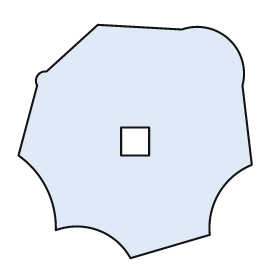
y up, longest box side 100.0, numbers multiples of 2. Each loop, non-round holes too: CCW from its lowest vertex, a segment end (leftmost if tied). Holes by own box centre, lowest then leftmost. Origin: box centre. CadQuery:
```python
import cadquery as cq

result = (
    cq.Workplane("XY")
    .moveTo(-2.0, -50.0)
    .lineTo(32.0, -40.0)
    .threePointArc((36.0, -22.0), (50.0, -10.0))
    .lineTo(46.0, 24.0)
    .threePointArc((40.0, 44.0), (20.0, 48.0))
    .lineTo(-16.0, 50.0)
    .lineTo(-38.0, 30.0)
    .threePointArc((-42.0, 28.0), (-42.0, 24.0))
    .lineTo(-50.0, -6.0)
    .threePointArc((-38.0, -20.0), (-34.0, -38.0))
    .threePointArc((-16.0, -38.0), (-2.0, -50.0))
    .close()
    .moveTo(-6.0, -6.0)
    .lineTo(6.0, -6.0)
    .lineTo(6.0, 6.0)
    .lineTo(-6.0, 6.0)
    .close()
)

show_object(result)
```